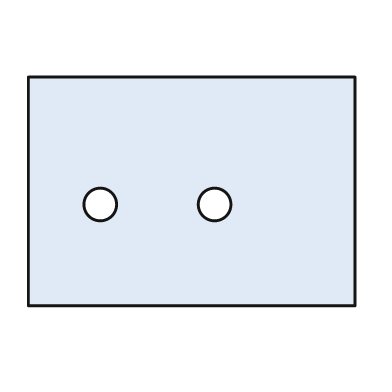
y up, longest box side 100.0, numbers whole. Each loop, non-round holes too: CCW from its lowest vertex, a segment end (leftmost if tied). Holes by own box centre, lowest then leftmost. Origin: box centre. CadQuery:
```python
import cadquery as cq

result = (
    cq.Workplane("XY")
    .moveTo(-50.0, -35.0)
    .lineTo(50.0, -35.0)
    .lineTo(50.0, 35.0)
    .lineTo(-50.0, 35.0)
    .close()
    .moveTo(-28.0, -4.0)
    .circle(5.0)
    .moveTo(7.0, -4.0)
    .circle(5.0)
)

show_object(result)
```